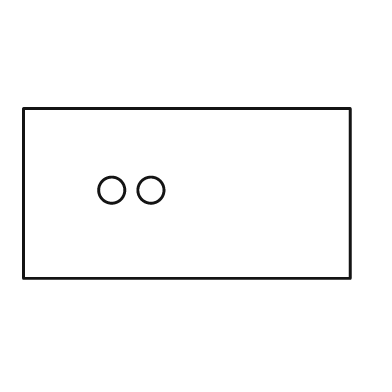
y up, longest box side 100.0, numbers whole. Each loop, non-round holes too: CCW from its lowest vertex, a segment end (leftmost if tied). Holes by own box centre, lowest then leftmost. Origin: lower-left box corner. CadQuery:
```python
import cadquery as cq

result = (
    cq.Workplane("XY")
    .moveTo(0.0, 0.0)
    .lineTo(100.0, 0.0)
    .lineTo(100.0, 52.0)
    .lineTo(0.0, 52.0)
    .close()
    .moveTo(27.0, 27.0)
    .circle(4.0)
    .moveTo(39.0, 27.0)
    .circle(4.0)
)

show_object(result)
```